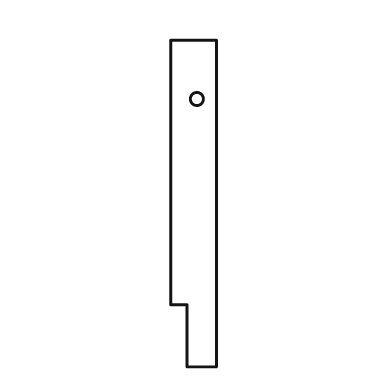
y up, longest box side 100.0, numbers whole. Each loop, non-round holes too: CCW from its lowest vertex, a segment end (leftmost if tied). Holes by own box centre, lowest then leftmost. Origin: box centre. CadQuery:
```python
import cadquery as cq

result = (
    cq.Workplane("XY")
    .moveTo(-2.0, -50.0)
    .lineTo(7.0, -50.0)
    .lineTo(7.0, 50.0)
    .lineTo(-7.0, 50.0)
    .lineTo(-7.0, -31.0)
    .lineTo(-2.0, -31.0)
    .close()
    .moveTo(1.0, 32.0)
    .circle(2.0)
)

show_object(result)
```